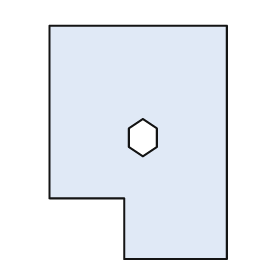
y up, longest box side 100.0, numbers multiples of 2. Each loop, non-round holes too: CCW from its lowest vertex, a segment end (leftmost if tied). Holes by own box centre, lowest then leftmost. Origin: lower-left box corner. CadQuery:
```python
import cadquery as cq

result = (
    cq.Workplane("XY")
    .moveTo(32.0, 0.0)
    .lineTo(76.0, 0.0)
    .lineTo(76.0, 100.0)
    .lineTo(0.0, 100.0)
    .lineTo(0.0, 26.0)
    .lineTo(32.0, 26.0)
    .close()
    .moveTo(40.0, 44.0)
    .lineTo(46.0, 48.0)
    .lineTo(46.0, 56.0)
    .lineTo(40.0, 60.0)
    .lineTo(34.0, 56.0)
    .lineTo(34.0, 48.0)
    .close()
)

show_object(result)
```